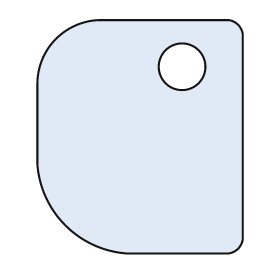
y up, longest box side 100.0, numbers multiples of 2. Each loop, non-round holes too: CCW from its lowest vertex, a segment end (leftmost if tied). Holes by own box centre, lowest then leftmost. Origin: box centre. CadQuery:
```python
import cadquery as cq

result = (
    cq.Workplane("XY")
    .moveTo(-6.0, -50.0)
    .lineTo(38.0, -50.0)
    .threePointArc((42.0, -48.0), (44.0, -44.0))
    .lineTo(44.0, 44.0)
    .threePointArc((42.0, 48.0), (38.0, 50.0))
    .lineTo(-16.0, 50.0)
    .threePointArc((-36.0, 42.0), (-44.0, 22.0))
    .lineTo(-44.0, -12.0)
    .threePointArc((-32.0, -38.0), (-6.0, -50.0))
    .close()
    .moveTo(18.0, 30.0)
    .circle(10.0)
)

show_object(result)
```